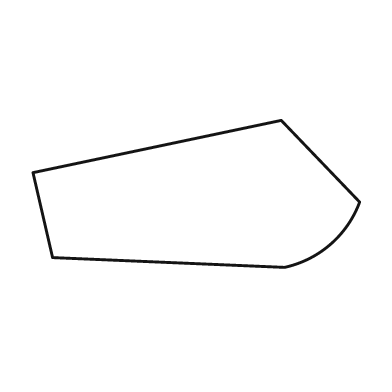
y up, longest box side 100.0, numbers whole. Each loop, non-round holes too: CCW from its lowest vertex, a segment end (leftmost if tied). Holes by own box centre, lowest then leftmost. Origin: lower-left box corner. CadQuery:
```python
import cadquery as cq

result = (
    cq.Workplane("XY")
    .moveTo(77.0, 0.0)
    .threePointArc((91.0, 7.0), (100.0, 20.0))
    .lineTo(76.0, 45.0)
    .lineTo(0.0, 29.0)
    .lineTo(6.0, 3.0)
    .close()
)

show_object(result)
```